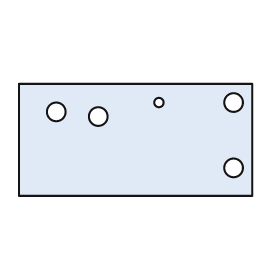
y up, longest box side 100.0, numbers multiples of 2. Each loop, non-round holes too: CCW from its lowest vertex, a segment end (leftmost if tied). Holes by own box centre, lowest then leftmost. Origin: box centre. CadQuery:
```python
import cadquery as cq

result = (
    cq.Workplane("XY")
    .moveTo(-50.0, -24.0)
    .lineTo(50.0, -24.0)
    .lineTo(50.0, 24.0)
    .lineTo(-50.0, 24.0)
    .close()
    .moveTo(42.0, -12.0)
    .circle(4.0)
    .moveTo(-16.0, 10.0)
    .circle(4.0)
    .moveTo(-34.0, 12.0)
    .circle(4.0)
    .moveTo(10.0, 16.0)
    .circle(2.0)
    .moveTo(42.0, 16.0)
    .circle(4.0)
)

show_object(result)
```